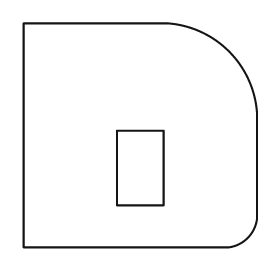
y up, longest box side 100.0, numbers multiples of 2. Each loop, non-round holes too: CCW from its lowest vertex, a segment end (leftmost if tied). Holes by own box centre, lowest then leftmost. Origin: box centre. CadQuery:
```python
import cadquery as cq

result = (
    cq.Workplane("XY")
    .moveTo(-50.0, -48.0)
    .lineTo(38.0, -48.0)
    .threePointArc((46.0, -44.0), (50.0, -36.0))
    .lineTo(50.0, 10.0)
    .threePointArc((38.0, 36.0), (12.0, 48.0))
    .lineTo(-50.0, 48.0)
    .close()
    .moveTo(-10.0, -30.0)
    .lineTo(10.0, -30.0)
    .lineTo(10.0, 2.0)
    .lineTo(-10.0, 2.0)
    .close()
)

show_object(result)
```